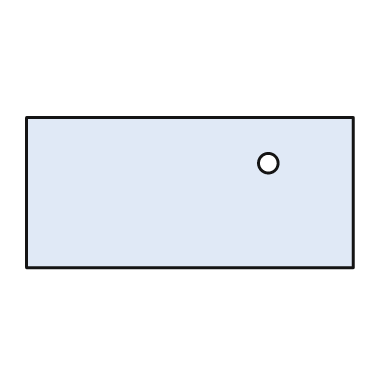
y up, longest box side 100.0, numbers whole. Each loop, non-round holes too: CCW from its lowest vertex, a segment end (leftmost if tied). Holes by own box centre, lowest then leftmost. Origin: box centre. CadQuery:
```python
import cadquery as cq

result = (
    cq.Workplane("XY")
    .moveTo(-50.0, -23.0)
    .lineTo(50.0, -23.0)
    .lineTo(50.0, 23.0)
    .lineTo(-50.0, 23.0)
    .close()
    .moveTo(24.0, 9.0)
    .circle(3.0)
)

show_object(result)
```